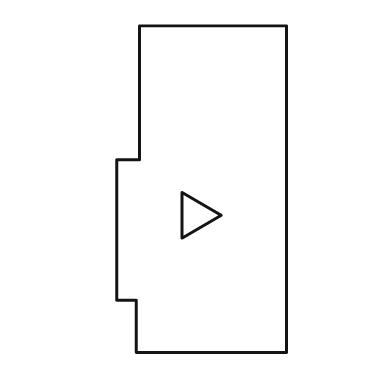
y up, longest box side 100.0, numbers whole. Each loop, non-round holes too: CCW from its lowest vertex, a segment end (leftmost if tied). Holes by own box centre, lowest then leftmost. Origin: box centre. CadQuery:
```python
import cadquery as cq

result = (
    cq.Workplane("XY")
    .moveTo(-20.0, -50.0)
    .lineTo(26.0, -50.0)
    .lineTo(26.0, 50.0)
    .lineTo(-19.0, 50.0)
    .lineTo(-19.0, 9.0)
    .lineTo(-26.0, 9.0)
    .lineTo(-26.0, -34.0)
    .lineTo(-20.0, -34.0)
    .close()
    .moveTo(-6.0, -15.0)
    .lineTo(6.0, -8.0)
    .lineTo(-6.0, -1.0)
    .close()
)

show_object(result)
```